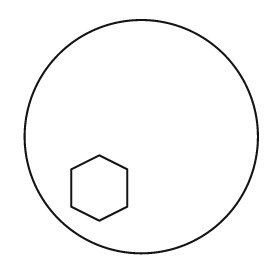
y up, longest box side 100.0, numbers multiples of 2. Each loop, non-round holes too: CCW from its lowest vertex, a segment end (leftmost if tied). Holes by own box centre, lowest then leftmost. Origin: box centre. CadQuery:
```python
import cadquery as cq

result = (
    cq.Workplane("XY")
    .moveTo(0.0, 0.0)
    .circle(50.0)
    .moveTo(-18.0, -36.0)
    .lineTo(-6.0, -30.0)
    .lineTo(-6.0, -14.0)
    .lineTo(-18.0, -8.0)
    .lineTo(-30.0, -14.0)
    .lineTo(-30.0, -30.0)
    .close()
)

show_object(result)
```